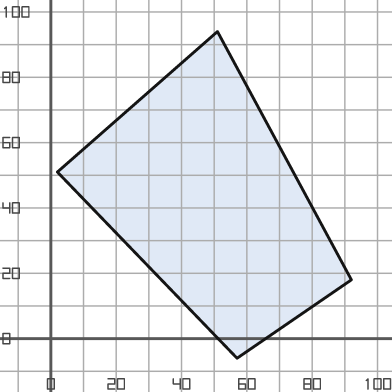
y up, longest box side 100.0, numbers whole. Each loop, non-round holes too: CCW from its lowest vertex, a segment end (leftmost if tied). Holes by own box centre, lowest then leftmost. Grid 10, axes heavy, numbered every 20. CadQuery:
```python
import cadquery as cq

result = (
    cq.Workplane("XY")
    .moveTo(57.0, -6.0)
    .lineTo(92.0, 18.0)
    .lineTo(51.0, 94.0)
    .lineTo(2.0, 51.0)
    .close()
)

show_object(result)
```